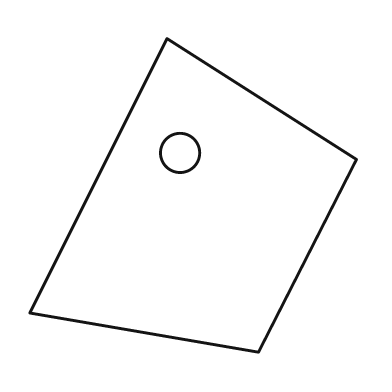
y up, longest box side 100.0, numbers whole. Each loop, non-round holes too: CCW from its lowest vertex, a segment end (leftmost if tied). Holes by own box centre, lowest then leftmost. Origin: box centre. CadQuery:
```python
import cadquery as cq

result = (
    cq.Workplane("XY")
    .moveTo(20.0, -48.0)
    .lineTo(50.0, 11.0)
    .lineTo(-8.0, 48.0)
    .lineTo(-50.0, -36.0)
    .close()
    .moveTo(-4.0, 13.0)
    .circle(6.0)
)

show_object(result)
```